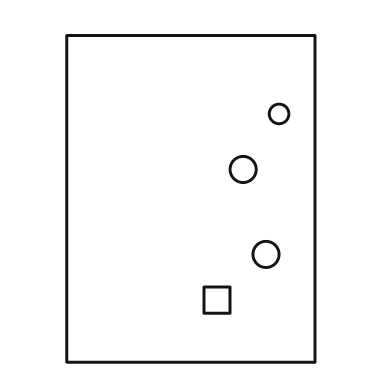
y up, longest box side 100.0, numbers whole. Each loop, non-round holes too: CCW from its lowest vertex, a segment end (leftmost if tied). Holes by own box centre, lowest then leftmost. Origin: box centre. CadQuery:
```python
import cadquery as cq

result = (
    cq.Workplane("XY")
    .moveTo(-38.0, -50.0)
    .lineTo(38.0, -50.0)
    .lineTo(38.0, 50.0)
    .lineTo(-38.0, 50.0)
    .close()
    .moveTo(4.0, -35.0)
    .lineTo(12.0, -35.0)
    .lineTo(12.0, -27.0)
    .lineTo(4.0, -27.0)
    .close()
    .moveTo(23.0, -17.0)
    .circle(4.0)
    .moveTo(16.0, 9.0)
    .circle(4.0)
    .moveTo(27.0, 26.0)
    .circle(3.0)
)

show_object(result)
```